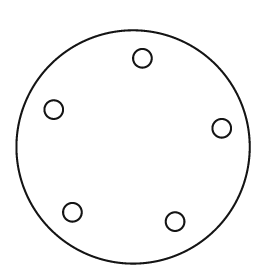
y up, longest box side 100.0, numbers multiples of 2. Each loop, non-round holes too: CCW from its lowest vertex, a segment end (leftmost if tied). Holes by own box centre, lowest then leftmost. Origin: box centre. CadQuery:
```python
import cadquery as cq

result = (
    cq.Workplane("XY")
    .moveTo(0.0, 0.0)
    .circle(50.0)
    .moveTo(18.0, -32.0)
    .circle(4.0)
    .moveTo(-26.0, -28.0)
    .circle(4.0)
    .moveTo(38.0, 8.0)
    .circle(4.0)
    .moveTo(-34.0, 16.0)
    .circle(4.0)
    .moveTo(4.0, 38.0)
    .circle(4.0)
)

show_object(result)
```